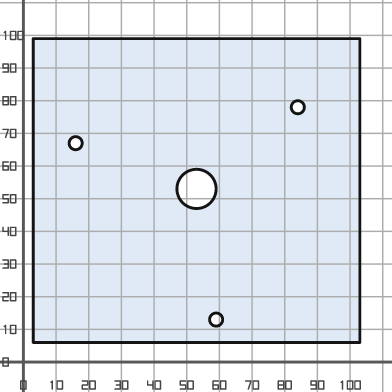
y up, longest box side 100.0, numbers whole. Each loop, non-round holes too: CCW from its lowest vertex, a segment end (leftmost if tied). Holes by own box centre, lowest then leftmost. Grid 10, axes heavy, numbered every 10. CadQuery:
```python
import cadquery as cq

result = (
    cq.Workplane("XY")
    .moveTo(3.0, 6.0)
    .lineTo(103.0, 6.0)
    .lineTo(103.0, 99.0)
    .lineTo(3.0, 99.0)
    .close()
    .moveTo(59.0, 13.0)
    .circle(2.0)
    .moveTo(53.0, 53.0)
    .circle(6.0)
    .moveTo(16.0, 67.0)
    .circle(2.0)
    .moveTo(84.0, 78.0)
    .circle(2.0)
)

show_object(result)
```